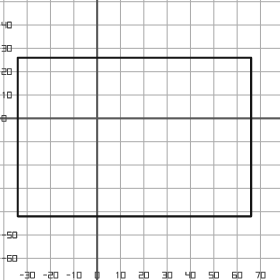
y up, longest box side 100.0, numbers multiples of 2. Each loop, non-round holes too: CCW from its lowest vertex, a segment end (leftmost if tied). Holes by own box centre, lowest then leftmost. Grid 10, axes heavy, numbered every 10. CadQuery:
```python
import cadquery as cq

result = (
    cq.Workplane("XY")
    .moveTo(-34.0, -42.0)
    .lineTo(66.0, -42.0)
    .lineTo(66.0, 26.0)
    .lineTo(-34.0, 26.0)
    .close()
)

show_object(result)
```